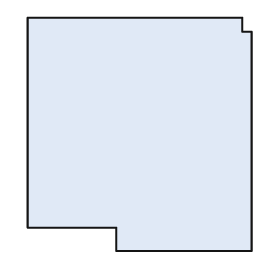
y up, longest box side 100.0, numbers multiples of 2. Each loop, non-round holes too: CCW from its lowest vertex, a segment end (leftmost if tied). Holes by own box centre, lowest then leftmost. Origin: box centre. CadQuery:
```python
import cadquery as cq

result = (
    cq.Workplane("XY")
    .moveTo(-10.0, -50.0)
    .lineTo(48.0, -50.0)
    .lineTo(48.0, 44.0)
    .lineTo(44.0, 44.0)
    .lineTo(44.0, 50.0)
    .lineTo(-48.0, 50.0)
    .lineTo(-48.0, -40.0)
    .lineTo(-10.0, -40.0)
    .close()
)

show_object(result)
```